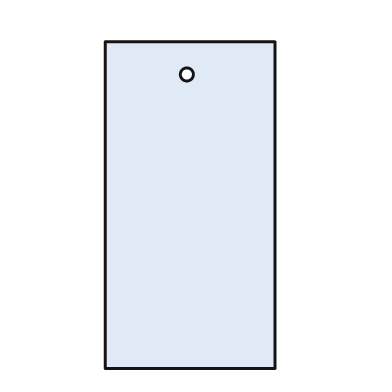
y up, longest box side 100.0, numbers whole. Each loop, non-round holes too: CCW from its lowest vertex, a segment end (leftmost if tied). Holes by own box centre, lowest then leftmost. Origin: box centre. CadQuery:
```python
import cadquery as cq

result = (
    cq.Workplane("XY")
    .moveTo(-26.0, -50.0)
    .lineTo(26.0, -50.0)
    .lineTo(26.0, 50.0)
    .lineTo(-26.0, 50.0)
    .close()
    .moveTo(-1.0, 40.0)
    .circle(2.0)
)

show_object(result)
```